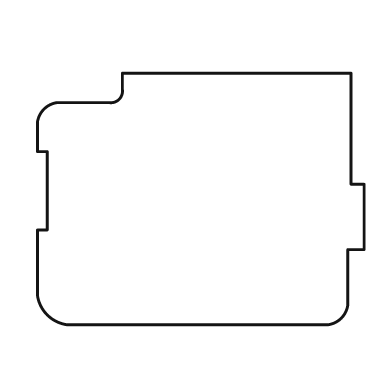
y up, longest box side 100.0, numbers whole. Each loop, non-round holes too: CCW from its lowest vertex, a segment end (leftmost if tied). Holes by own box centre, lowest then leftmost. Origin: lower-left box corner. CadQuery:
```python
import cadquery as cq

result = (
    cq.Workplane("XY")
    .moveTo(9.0, 0.0)
    .lineTo(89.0, 0.0)
    .threePointArc((93.0, 2.0), (95.0, 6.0))
    .lineTo(95.0, 23.0)
    .lineTo(100.0, 23.0)
    .lineTo(100.0, 43.0)
    .lineTo(96.0, 43.0)
    .lineTo(96.0, 77.0)
    .lineTo(26.0, 77.0)
    .lineTo(26.0, 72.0)
    .threePointArc((25.0, 69.0), (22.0, 68.0))
    .lineTo(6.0, 68.0)
    .threePointArc((2.0, 66.0), (0.0, 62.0))
    .lineTo(0.0, 53.0)
    .lineTo(3.0, 53.0)
    .lineTo(3.0, 29.0)
    .lineTo(0.0, 29.0)
    .lineTo(0.0, 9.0)
    .threePointArc((3.0, 3.0), (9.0, 0.0))
    .close()
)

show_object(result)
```